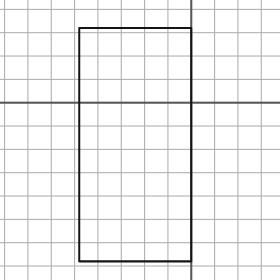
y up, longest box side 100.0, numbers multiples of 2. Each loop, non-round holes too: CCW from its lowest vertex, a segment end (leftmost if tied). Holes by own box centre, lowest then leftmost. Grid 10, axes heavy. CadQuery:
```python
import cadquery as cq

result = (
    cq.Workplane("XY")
    .moveTo(-48.0, -68.0)
    .lineTo(0.0, -68.0)
    .lineTo(0.0, 32.0)
    .lineTo(-48.0, 32.0)
    .close()
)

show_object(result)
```